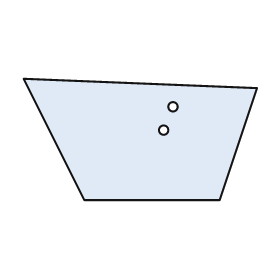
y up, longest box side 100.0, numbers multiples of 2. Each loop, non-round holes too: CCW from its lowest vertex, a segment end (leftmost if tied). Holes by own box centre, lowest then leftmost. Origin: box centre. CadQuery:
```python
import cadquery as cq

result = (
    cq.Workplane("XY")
    .moveTo(-24.0, -26.0)
    .lineTo(34.0, -26.0)
    .lineTo(50.0, 22.0)
    .lineTo(-50.0, 26.0)
    .close()
    .moveTo(10.0, 4.0)
    .circle(2.0)
    .moveTo(14.0, 14.0)
    .circle(2.0)
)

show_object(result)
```